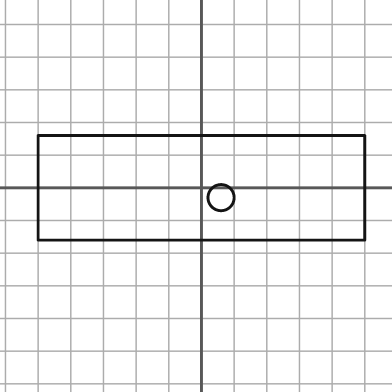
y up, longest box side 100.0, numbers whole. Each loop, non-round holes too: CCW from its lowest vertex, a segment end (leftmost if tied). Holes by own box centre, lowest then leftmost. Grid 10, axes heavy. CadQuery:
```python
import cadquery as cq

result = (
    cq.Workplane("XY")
    .moveTo(-50.0, -16.0)
    .lineTo(50.0, -16.0)
    .lineTo(50.0, 16.0)
    .lineTo(-50.0, 16.0)
    .close()
    .moveTo(6.0, -3.0)
    .circle(4.0)
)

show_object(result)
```